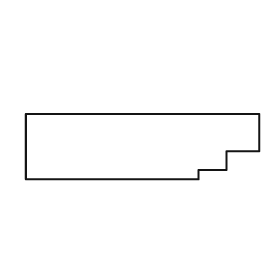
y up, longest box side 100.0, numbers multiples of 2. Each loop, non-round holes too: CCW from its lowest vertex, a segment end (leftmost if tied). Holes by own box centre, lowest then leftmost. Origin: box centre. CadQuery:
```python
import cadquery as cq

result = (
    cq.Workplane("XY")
    .moveTo(-50.0, -14.0)
    .lineTo(24.0, -14.0)
    .lineTo(24.0, -10.0)
    .lineTo(36.0, -10.0)
    .lineTo(36.0, -2.0)
    .lineTo(50.0, -2.0)
    .lineTo(50.0, 14.0)
    .lineTo(-50.0, 14.0)
    .close()
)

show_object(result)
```